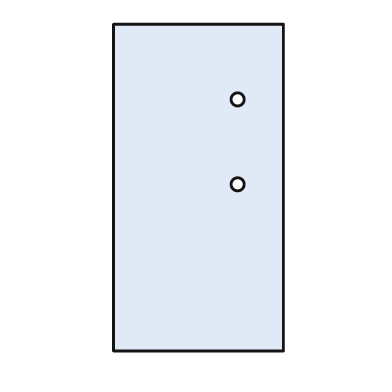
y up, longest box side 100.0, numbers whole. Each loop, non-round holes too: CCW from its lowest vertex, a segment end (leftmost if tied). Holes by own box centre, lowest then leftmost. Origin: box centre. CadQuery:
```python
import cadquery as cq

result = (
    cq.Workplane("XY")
    .moveTo(-26.0, -50.0)
    .lineTo(26.0, -50.0)
    .lineTo(26.0, 50.0)
    .lineTo(-26.0, 50.0)
    .close()
    .moveTo(12.0, 1.0)
    .circle(2.0)
    .moveTo(12.0, 27.0)
    .circle(2.0)
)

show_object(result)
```